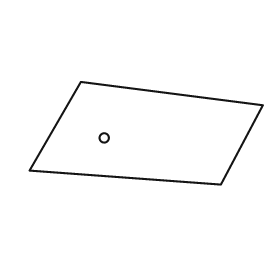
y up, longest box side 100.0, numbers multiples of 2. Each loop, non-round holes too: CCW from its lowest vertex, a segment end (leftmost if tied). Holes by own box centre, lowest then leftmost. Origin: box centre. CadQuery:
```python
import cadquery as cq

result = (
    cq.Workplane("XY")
    .moveTo(32.0, -22.0)
    .lineTo(50.0, 12.0)
    .lineTo(-28.0, 22.0)
    .lineTo(-50.0, -16.0)
    .close()
    .moveTo(-18.0, -2.0)
    .circle(2.0)
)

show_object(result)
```